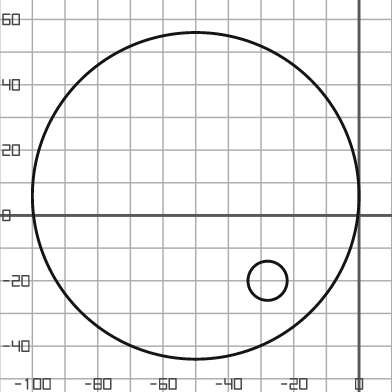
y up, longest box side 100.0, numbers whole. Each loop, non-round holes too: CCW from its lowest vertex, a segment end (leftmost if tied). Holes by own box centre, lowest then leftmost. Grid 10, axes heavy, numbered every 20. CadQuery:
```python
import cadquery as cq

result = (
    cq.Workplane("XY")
    .moveTo(-50.0, 6.0)
    .circle(50.0)
    .moveTo(-28.0, -20.0)
    .circle(6.0)
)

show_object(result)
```